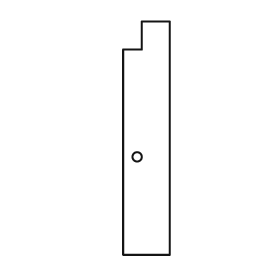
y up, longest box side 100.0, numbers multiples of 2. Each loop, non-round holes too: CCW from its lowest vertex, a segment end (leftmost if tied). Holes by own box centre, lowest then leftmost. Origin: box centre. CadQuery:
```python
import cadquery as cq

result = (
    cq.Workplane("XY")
    .moveTo(-10.0, -50.0)
    .lineTo(10.0, -50.0)
    .lineTo(10.0, 50.0)
    .lineTo(-2.0, 50.0)
    .lineTo(-2.0, 38.0)
    .lineTo(-10.0, 38.0)
    .close()
    .moveTo(-4.0, -8.0)
    .circle(2.0)
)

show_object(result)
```